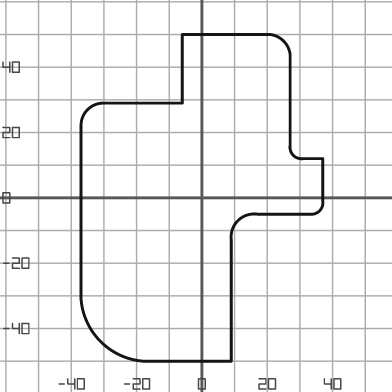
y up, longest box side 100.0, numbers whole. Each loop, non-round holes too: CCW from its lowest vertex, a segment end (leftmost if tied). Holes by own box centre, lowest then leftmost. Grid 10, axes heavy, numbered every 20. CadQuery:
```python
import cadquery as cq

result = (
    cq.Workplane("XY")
    .moveTo(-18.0, -50.0)
    .lineTo(9.0, -50.0)
    .lineTo(9.0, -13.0)
    .threePointArc((11.0, -7.0), (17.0, -5.0))
    .lineTo(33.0, -5.0)
    .threePointArc((36.0, -4.0), (37.0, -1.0))
    .lineTo(37.0, 12.0)
    .lineTo(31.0, 12.0)
    .threePointArc((28.0, 13.0), (27.0, 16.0))
    .lineTo(27.0, 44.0)
    .threePointArc((25.0, 48.0), (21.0, 50.0))
    .lineTo(-6.0, 50.0)
    .lineTo(-6.0, 29.0)
    .lineTo(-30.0, 29.0)
    .threePointArc((-35.0, 27.0), (-37.0, 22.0))
    .lineTo(-37.0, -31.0)
    .threePointArc((-31.0, -44.0), (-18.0, -50.0))
    .close()
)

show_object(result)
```